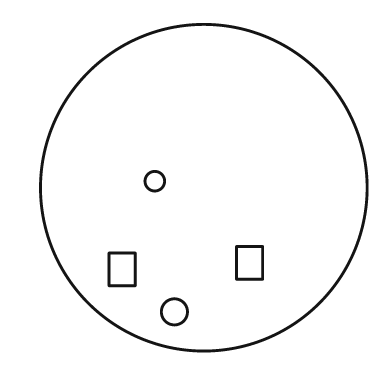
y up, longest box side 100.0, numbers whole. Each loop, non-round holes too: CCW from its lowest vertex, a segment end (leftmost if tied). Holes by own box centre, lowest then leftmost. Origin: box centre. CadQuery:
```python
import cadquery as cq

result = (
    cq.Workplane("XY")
    .moveTo(0.0, 0.0)
    .circle(50.0)
    .moveTo(-9.0, -38.0)
    .circle(4.0)
    .moveTo(-29.0, -30.0)
    .lineTo(-21.0, -30.0)
    .lineTo(-21.0, -20.0)
    .lineTo(-29.0, -20.0)
    .close()
    .moveTo(10.0, -28.0)
    .lineTo(18.0, -28.0)
    .lineTo(18.0, -18.0)
    .lineTo(10.0, -18.0)
    .close()
    .moveTo(-15.0, 2.0)
    .circle(3.0)
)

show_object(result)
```